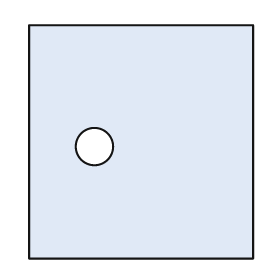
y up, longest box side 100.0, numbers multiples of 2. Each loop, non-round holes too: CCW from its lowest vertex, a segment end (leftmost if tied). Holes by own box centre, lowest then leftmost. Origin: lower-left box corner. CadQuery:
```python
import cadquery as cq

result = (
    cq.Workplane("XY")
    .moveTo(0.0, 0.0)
    .lineTo(96.0, 0.0)
    .lineTo(96.0, 100.0)
    .lineTo(0.0, 100.0)
    .close()
    .moveTo(28.0, 48.0)
    .circle(8.0)
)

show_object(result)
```